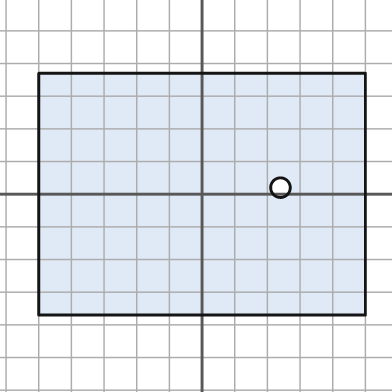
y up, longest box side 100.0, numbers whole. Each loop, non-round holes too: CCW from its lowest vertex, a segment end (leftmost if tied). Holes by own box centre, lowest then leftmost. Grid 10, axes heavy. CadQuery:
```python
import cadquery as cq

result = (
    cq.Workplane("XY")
    .moveTo(-50.0, -37.0)
    .lineTo(50.0, -37.0)
    .lineTo(50.0, 37.0)
    .lineTo(-50.0, 37.0)
    .close()
    .moveTo(24.0, 2.0)
    .circle(3.0)
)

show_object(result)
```